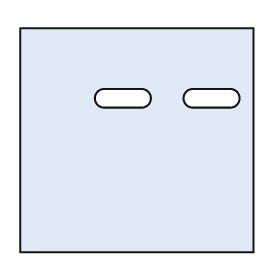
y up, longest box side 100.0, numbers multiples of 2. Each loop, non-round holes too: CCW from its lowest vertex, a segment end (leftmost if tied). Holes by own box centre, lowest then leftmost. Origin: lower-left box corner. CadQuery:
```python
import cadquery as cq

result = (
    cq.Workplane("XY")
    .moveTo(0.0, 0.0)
    .lineTo(100.0, 0.0)
    .lineTo(100.0, 96.0)
    .lineTo(0.0, 96.0)
    .close()
    .moveTo(36.0, 62.0)
    .lineTo(52.0, 62.0)
    .threePointArc((56.0, 66.0), (52.0, 70.0))
    .lineTo(36.0, 70.0)
    .threePointArc((32.0, 66.0), (36.0, 62.0))
    .close()
    .moveTo(74.0, 62.0)
    .lineTo(90.0, 62.0)
    .threePointArc((94.0, 66.0), (90.0, 70.0))
    .lineTo(74.0, 70.0)
    .threePointArc((70.0, 66.0), (74.0, 62.0))
    .close()
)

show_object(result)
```